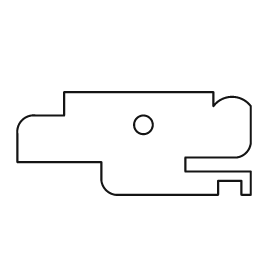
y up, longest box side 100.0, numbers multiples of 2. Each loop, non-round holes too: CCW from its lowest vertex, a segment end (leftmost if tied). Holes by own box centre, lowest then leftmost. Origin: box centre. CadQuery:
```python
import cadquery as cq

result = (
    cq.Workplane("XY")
    .moveTo(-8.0, -22.0)
    .lineTo(36.0, -22.0)
    .lineTo(36.0, -16.0)
    .lineTo(46.0, -16.0)
    .lineTo(46.0, -22.0)
    .lineTo(50.0, -22.0)
    .lineTo(50.0, -12.0)
    .lineTo(22.0, -12.0)
    .lineTo(22.0, -6.0)
    .lineTo(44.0, -6.0)
    .threePointArc((48.0, -4.0), (50.0, 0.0))
    .lineTo(50.0, 16.0)
    .threePointArc((42.0, 20.0), (34.0, 16.0))
    .lineTo(34.0, 22.0)
    .lineTo(-30.0, 22.0)
    .lineTo(-30.0, 12.0)
    .lineTo(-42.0, 12.0)
    .threePointArc((-48.0, 10.0), (-50.0, 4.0))
    .lineTo(-50.0, -8.0)
    .lineTo(-14.0, -8.0)
    .lineTo(-14.0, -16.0)
    .threePointArc((-12.0, -20.0), (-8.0, -22.0))
    .close()
    .moveTo(4.0, 8.0)
    .circle(4.0)
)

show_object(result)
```